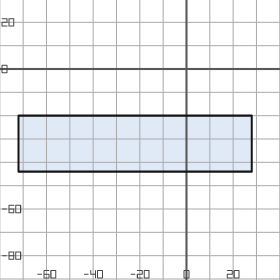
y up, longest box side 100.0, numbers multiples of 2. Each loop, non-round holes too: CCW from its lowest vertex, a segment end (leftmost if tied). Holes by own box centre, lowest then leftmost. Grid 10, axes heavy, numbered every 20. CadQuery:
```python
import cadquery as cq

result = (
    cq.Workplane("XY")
    .moveTo(-72.0, -44.0)
    .lineTo(28.0, -44.0)
    .lineTo(28.0, -20.0)
    .lineTo(-72.0, -20.0)
    .close()
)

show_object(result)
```